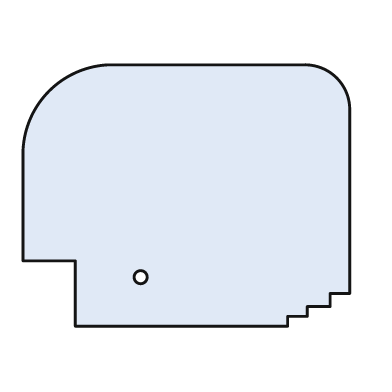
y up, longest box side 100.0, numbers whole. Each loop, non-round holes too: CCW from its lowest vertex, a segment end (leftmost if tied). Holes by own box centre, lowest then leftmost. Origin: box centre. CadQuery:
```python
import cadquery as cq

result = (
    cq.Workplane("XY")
    .moveTo(-34.0, -40.0)
    .lineTo(31.0, -40.0)
    .lineTo(31.0, -37.0)
    .lineTo(37.0, -37.0)
    .lineTo(37.0, -34.0)
    .lineTo(44.0, -34.0)
    .lineTo(44.0, -30.0)
    .lineTo(50.0, -30.0)
    .lineTo(50.0, 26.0)
    .threePointArc((46.0, 36.0), (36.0, 40.0))
    .lineTo(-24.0, 40.0)
    .threePointArc((-42.0, 32.0), (-50.0, 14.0))
    .lineTo(-50.0, -20.0)
    .lineTo(-34.0, -20.0)
    .close()
    .moveTo(-14.0, -25.0)
    .circle(2.0)
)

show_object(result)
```